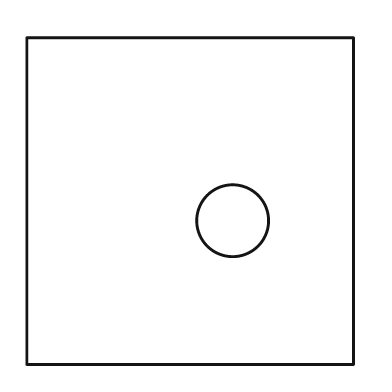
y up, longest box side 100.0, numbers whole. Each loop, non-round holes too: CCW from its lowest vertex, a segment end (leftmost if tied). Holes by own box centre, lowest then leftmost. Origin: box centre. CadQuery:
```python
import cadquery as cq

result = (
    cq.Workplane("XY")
    .moveTo(-50.0, -50.0)
    .lineTo(50.0, -50.0)
    .lineTo(50.0, 50.0)
    .lineTo(-50.0, 50.0)
    .close()
    .moveTo(13.0, -6.0)
    .circle(11.0)
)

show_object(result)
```